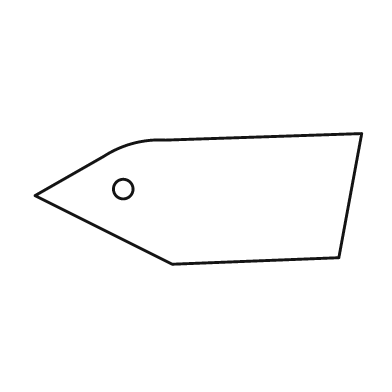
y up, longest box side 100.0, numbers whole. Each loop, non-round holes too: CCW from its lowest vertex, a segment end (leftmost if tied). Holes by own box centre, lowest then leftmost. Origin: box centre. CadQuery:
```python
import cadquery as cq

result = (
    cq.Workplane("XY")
    .moveTo(-8.0, -20.0)
    .lineTo(43.0, -18.0)
    .lineTo(50.0, 20.0)
    .lineTo(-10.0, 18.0)
    .threePointArc((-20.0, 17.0), (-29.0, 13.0))
    .lineTo(-50.0, 1.0)
    .close()
    .moveTo(-23.0, 3.0)
    .circle(3.0)
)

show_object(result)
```